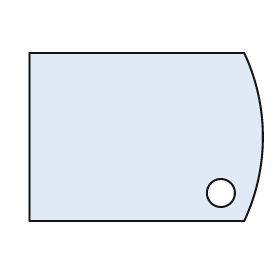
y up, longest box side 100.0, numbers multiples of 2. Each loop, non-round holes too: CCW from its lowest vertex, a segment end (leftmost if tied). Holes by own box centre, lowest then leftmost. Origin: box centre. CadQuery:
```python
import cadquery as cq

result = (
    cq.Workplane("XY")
    .moveTo(-50.0, -36.0)
    .lineTo(42.0, -36.0)
    .threePointArc((50.0, 0.0), (42.0, 36.0))
    .lineTo(-50.0, 36.0)
    .close()
    .moveTo(32.0, -24.0)
    .circle(6.0)
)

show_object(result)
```